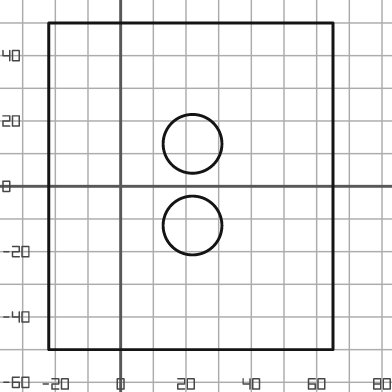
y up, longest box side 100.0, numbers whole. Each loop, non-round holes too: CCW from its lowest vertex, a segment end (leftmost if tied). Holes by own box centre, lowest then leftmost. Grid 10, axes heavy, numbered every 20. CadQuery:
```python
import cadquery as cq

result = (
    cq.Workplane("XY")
    .moveTo(-22.0, -50.0)
    .lineTo(65.0, -50.0)
    .lineTo(65.0, 50.0)
    .lineTo(-22.0, 50.0)
    .close()
    .moveTo(22.0, -12.0)
    .circle(9.0)
    .moveTo(22.0, 13.0)
    .circle(9.0)
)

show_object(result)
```